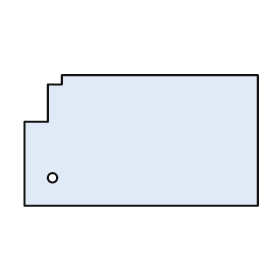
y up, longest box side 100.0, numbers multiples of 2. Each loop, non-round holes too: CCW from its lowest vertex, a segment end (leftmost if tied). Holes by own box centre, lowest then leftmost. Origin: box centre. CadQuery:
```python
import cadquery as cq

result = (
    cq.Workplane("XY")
    .moveTo(-50.0, -28.0)
    .lineTo(50.0, -28.0)
    .lineTo(50.0, 28.0)
    .lineTo(-34.0, 28.0)
    .lineTo(-34.0, 24.0)
    .lineTo(-40.0, 24.0)
    .lineTo(-40.0, 8.0)
    .lineTo(-50.0, 8.0)
    .close()
    .moveTo(-38.0, -16.0)
    .circle(2.0)
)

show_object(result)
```